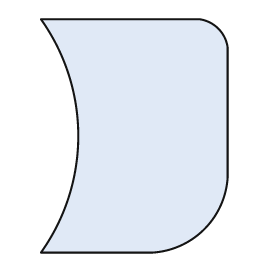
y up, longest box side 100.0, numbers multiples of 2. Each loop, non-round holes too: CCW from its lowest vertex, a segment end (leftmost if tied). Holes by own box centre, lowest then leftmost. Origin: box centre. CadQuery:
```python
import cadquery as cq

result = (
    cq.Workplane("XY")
    .moveTo(-40.0, -50.0)
    .lineTo(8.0, -50.0)
    .threePointArc((30.0, -40.0), (40.0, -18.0))
    .lineTo(40.0, 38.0)
    .threePointArc((36.0, 46.0), (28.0, 50.0))
    .lineTo(-40.0, 50.0)
    .threePointArc((-24.0, 0.0), (-40.0, -50.0))
    .close()
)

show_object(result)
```